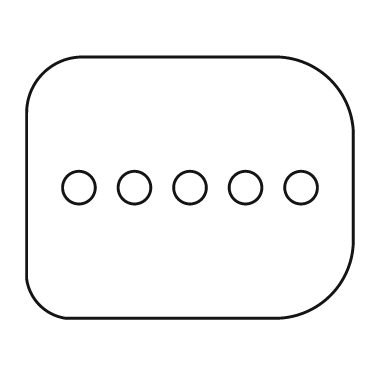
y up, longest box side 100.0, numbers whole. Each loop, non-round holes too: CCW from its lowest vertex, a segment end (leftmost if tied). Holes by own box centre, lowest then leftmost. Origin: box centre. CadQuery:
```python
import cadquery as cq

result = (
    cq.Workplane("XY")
    .moveTo(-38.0, -40.0)
    .lineTo(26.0, -40.0)
    .threePointArc((43.0, -33.0), (50.0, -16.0))
    .lineTo(50.0, 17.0)
    .threePointArc((43.0, 33.0), (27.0, 40.0))
    .lineTo(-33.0, 40.0)
    .threePointArc((-45.0, 35.0), (-50.0, 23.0))
    .lineTo(-50.0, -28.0)
    .threePointArc((-46.0, -36.0), (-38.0, -40.0))
    .close()
    .moveTo(-34.0, 0.0)
    .circle(5.0)
    .moveTo(-17.0, 0.0)
    .circle(5.0)
    .moveTo(0.0, 0.0)
    .circle(5.0)
    .moveTo(17.0, 0.0)
    .circle(5.0)
    .moveTo(34.0, 0.0)
    .circle(5.0)
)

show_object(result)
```